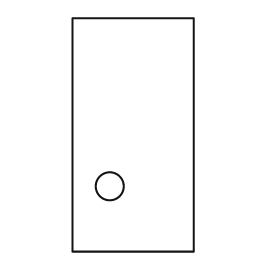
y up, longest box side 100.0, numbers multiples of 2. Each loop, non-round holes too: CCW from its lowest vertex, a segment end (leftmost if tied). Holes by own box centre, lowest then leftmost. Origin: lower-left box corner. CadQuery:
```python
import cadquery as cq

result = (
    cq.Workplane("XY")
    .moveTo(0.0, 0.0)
    .lineTo(52.0, 0.0)
    .lineTo(52.0, 100.0)
    .lineTo(0.0, 100.0)
    .close()
    .moveTo(16.0, 28.0)
    .circle(6.0)
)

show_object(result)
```